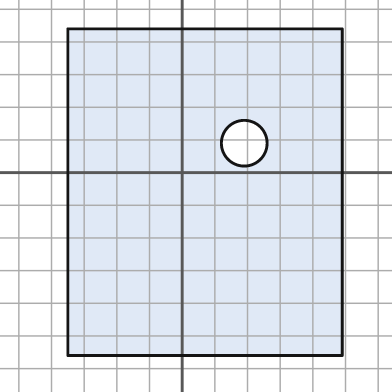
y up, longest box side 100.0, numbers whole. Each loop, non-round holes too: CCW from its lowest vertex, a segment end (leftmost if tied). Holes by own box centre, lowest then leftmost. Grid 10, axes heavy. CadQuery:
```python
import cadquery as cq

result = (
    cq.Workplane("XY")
    .moveTo(-35.0, -56.0)
    .lineTo(49.0, -56.0)
    .lineTo(49.0, 44.0)
    .lineTo(-35.0, 44.0)
    .close()
    .moveTo(19.0, 9.0)
    .circle(7.0)
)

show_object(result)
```